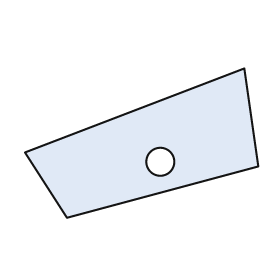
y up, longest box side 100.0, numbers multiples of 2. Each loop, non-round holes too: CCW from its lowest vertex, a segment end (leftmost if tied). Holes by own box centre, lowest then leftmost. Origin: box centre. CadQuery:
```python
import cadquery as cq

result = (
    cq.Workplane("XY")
    .moveTo(-32.0, -32.0)
    .lineTo(50.0, -10.0)
    .lineTo(44.0, 32.0)
    .lineTo(-50.0, -4.0)
    .close()
    .moveTo(8.0, -8.0)
    .circle(6.0)
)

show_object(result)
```